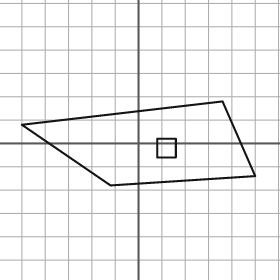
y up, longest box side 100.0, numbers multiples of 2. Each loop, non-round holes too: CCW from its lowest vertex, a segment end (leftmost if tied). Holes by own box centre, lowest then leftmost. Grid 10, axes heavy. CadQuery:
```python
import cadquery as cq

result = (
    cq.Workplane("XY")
    .moveTo(-12.0, -18.0)
    .lineTo(50.0, -14.0)
    .lineTo(36.0, 18.0)
    .lineTo(-50.0, 8.0)
    .close()
    .moveTo(8.0, -6.0)
    .lineTo(16.0, -6.0)
    .lineTo(16.0, 2.0)
    .lineTo(8.0, 2.0)
    .close()
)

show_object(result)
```